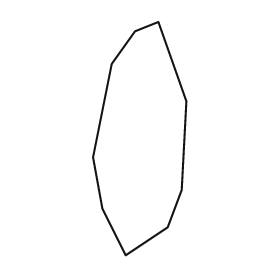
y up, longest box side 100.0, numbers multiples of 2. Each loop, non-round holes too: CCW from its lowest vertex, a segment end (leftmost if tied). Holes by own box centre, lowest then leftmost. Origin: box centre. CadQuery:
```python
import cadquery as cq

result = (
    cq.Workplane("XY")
    .moveTo(-6.0, -50.0)
    .lineTo(12.0, -38.0)
    .lineTo(18.0, -22.0)
    .lineTo(20.0, 16.0)
    .lineTo(8.0, 50.0)
    .lineTo(-2.0, 46.0)
    .lineTo(-12.0, 32.0)
    .lineTo(-20.0, -8.0)
    .lineTo(-16.0, -30.0)
    .close()
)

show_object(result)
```